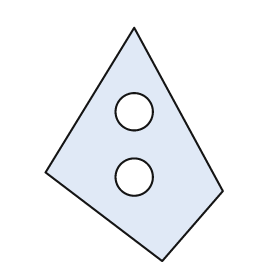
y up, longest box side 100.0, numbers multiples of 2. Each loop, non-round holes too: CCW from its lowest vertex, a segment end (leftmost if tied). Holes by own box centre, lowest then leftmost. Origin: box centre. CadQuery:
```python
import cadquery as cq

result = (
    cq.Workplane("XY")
    .moveTo(12.0, -50.0)
    .lineTo(38.0, -20.0)
    .lineTo(0.0, 50.0)
    .lineTo(-38.0, -12.0)
    .close()
    .moveTo(0.0, -14.0)
    .circle(8.0)
    .moveTo(0.0, 14.0)
    .circle(8.0)
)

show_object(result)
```